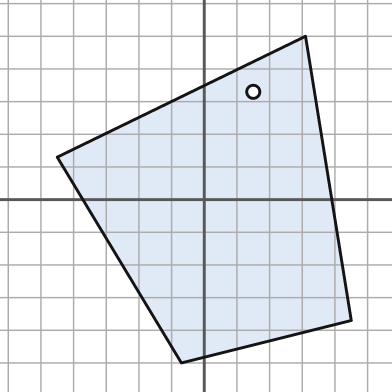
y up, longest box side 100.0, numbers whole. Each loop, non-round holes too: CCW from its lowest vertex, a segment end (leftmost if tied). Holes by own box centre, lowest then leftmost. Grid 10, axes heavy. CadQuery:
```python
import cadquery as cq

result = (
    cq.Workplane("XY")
    .moveTo(-7.0, -50.0)
    .lineTo(45.0, -37.0)
    .lineTo(31.0, 50.0)
    .lineTo(-45.0, 13.0)
    .close()
    .moveTo(15.0, 33.0)
    .circle(2.0)
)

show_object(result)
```